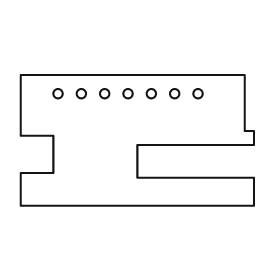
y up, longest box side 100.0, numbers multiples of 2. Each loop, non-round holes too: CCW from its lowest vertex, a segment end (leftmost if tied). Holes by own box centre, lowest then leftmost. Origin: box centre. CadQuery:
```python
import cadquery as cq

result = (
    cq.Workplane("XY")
    .moveTo(-50.0, -28.0)
    .lineTo(50.0, -28.0)
    .lineTo(50.0, -16.0)
    .lineTo(0.0, -16.0)
    .lineTo(0.0, -2.0)
    .lineTo(50.0, -2.0)
    .lineTo(50.0, 4.0)
    .lineTo(46.0, 4.0)
    .lineTo(46.0, 28.0)
    .lineTo(-50.0, 28.0)
    .lineTo(-50.0, 2.0)
    .lineTo(-36.0, 2.0)
    .lineTo(-36.0, -14.0)
    .lineTo(-50.0, -14.0)
    .close()
    .moveTo(-34.0, 20.0)
    .circle(2.0)
    .moveTo(-24.0, 20.0)
    .circle(2.0)
    .moveTo(-14.0, 20.0)
    .circle(2.0)
    .moveTo(-4.0, 20.0)
    .circle(2.0)
    .moveTo(6.0, 20.0)
    .circle(2.0)
    .moveTo(16.0, 20.0)
    .circle(2.0)
    .moveTo(26.0, 20.0)
    .circle(2.0)
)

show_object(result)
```